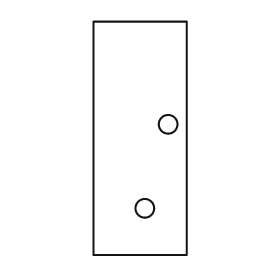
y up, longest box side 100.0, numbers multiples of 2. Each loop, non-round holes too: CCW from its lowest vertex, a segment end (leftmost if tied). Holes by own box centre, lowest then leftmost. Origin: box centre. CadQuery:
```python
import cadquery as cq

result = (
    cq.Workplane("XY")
    .moveTo(-20.0, -50.0)
    .lineTo(20.0, -50.0)
    .lineTo(20.0, 50.0)
    .lineTo(-20.0, 50.0)
    .close()
    .moveTo(2.0, -30.0)
    .circle(4.0)
    .moveTo(12.0, 6.0)
    .circle(4.0)
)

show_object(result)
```